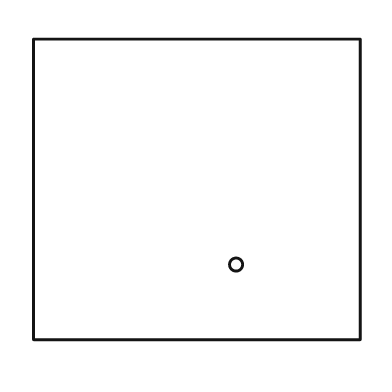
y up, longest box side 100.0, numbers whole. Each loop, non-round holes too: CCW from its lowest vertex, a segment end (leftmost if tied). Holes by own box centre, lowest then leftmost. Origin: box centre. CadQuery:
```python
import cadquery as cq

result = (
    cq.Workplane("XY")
    .moveTo(-50.0, -46.0)
    .lineTo(50.0, -46.0)
    .lineTo(50.0, 46.0)
    .lineTo(-50.0, 46.0)
    .close()
    .moveTo(12.0, -23.0)
    .circle(2.0)
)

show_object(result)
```